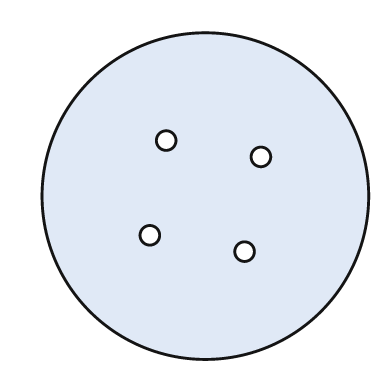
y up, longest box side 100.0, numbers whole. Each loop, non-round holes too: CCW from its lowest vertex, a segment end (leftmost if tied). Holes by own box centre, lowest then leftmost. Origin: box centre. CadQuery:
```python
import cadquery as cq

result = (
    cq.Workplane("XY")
    .moveTo(0.0, 0.0)
    .circle(50.0)
    .moveTo(12.0, -17.0)
    .circle(3.0)
    .moveTo(-17.0, -12.0)
    .circle(3.0)
    .moveTo(17.0, 12.0)
    .circle(3.0)
    .moveTo(-12.0, 17.0)
    .circle(3.0)
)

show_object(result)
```